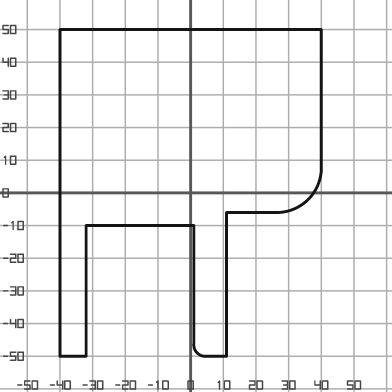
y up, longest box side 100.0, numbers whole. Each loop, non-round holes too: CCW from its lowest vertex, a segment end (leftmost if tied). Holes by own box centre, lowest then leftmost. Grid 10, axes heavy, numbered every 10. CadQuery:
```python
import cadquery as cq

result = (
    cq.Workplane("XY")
    .moveTo(-40.0, -50.0)
    .lineTo(-32.0, -50.0)
    .lineTo(-32.0, -10.0)
    .lineTo(1.0, -10.0)
    .lineTo(1.0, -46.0)
    .threePointArc((2.0, -49.0), (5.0, -50.0))
    .lineTo(11.0, -50.0)
    .lineTo(11.0, -6.0)
    .lineTo(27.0, -6.0)
    .threePointArc((36.0, -2.0), (40.0, 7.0))
    .lineTo(40.0, 50.0)
    .lineTo(-40.0, 50.0)
    .close()
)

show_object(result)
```